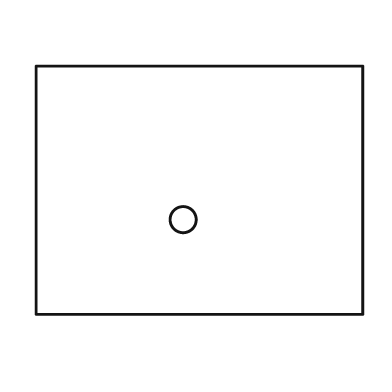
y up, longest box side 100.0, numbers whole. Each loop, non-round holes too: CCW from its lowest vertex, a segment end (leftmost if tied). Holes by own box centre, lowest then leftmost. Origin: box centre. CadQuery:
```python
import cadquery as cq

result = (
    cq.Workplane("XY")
    .moveTo(-50.0, -38.0)
    .lineTo(50.0, -38.0)
    .lineTo(50.0, 38.0)
    .lineTo(-50.0, 38.0)
    .close()
    .moveTo(-5.0, -9.0)
    .circle(4.0)
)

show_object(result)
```